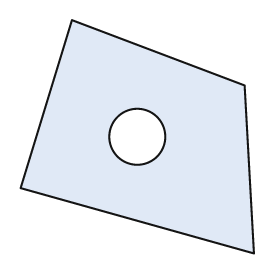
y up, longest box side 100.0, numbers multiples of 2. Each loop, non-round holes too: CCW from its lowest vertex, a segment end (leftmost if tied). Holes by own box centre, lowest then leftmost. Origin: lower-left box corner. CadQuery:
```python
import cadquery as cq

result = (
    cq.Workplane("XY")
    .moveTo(100.0, 0.0)
    .lineTo(96.0, 72.0)
    .lineTo(22.0, 100.0)
    .lineTo(0.0, 28.0)
    .close()
    .moveTo(50.0, 50.0)
    .circle(12.0)
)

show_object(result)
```